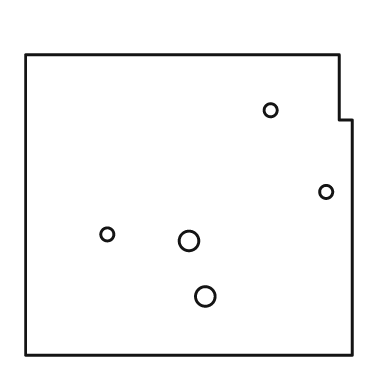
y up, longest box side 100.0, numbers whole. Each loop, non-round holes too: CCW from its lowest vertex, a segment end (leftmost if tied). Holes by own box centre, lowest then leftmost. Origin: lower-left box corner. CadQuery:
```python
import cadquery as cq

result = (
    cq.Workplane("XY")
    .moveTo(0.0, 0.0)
    .lineTo(100.0, 0.0)
    .lineTo(100.0, 72.0)
    .lineTo(96.0, 72.0)
    .lineTo(96.0, 92.0)
    .lineTo(0.0, 92.0)
    .close()
    .moveTo(55.0, 18.0)
    .circle(3.0)
    .moveTo(50.0, 35.0)
    .circle(3.0)
    .moveTo(25.0, 37.0)
    .circle(2.0)
    .moveTo(92.0, 50.0)
    .circle(2.0)
    .moveTo(75.0, 75.0)
    .circle(2.0)
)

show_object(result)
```